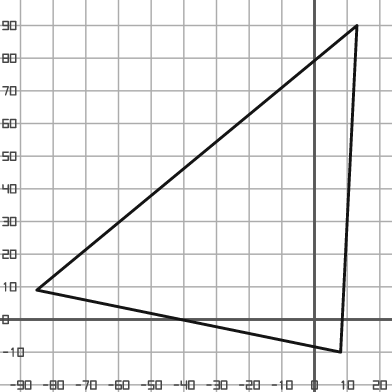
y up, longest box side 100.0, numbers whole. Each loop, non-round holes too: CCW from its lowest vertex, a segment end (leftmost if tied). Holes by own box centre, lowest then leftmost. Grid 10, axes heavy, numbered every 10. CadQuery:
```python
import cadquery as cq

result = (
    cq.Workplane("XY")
    .moveTo(8.0, -10.0)
    .lineTo(13.0, 90.0)
    .lineTo(-85.0, 9.0)
    .close()
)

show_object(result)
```